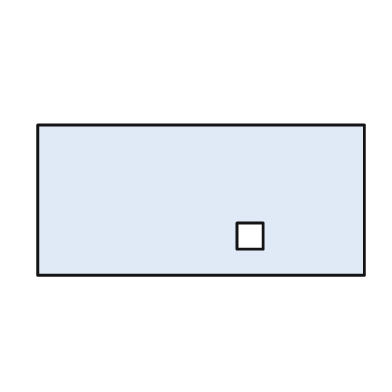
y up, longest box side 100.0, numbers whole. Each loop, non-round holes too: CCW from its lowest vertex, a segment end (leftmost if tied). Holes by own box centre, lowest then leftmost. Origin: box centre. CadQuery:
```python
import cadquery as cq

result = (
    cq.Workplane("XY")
    .moveTo(-50.0, -23.0)
    .lineTo(50.0, -23.0)
    .lineTo(50.0, 23.0)
    .lineTo(-50.0, 23.0)
    .close()
    .moveTo(11.0, -15.0)
    .lineTo(19.0, -15.0)
    .lineTo(19.0, -7.0)
    .lineTo(11.0, -7.0)
    .close()
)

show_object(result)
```